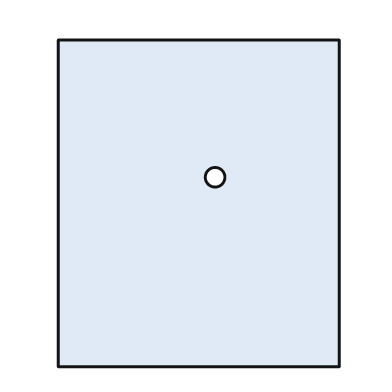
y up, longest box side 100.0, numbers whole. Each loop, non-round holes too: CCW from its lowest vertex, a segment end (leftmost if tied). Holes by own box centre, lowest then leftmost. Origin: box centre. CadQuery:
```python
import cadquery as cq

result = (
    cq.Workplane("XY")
    .moveTo(-43.0, -50.0)
    .lineTo(43.0, -50.0)
    .lineTo(43.0, 50.0)
    .lineTo(-43.0, 50.0)
    .close()
    .moveTo(5.0, 8.0)
    .circle(3.0)
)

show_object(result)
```